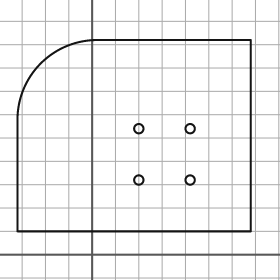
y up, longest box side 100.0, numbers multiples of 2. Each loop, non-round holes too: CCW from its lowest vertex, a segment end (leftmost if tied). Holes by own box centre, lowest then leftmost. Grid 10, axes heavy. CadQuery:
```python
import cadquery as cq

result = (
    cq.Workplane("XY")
    .moveTo(-32.0, 10.0)
    .lineTo(68.0, 10.0)
    .lineTo(68.0, 92.0)
    .lineTo(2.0, 92.0)
    .threePointArc((-22.0, 82.0), (-32.0, 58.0))
    .close()
    .moveTo(20.0, 32.0)
    .circle(2.0)
    .moveTo(42.0, 32.0)
    .circle(2.0)
    .moveTo(20.0, 54.0)
    .circle(2.0)
    .moveTo(42.0, 54.0)
    .circle(2.0)
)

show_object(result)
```